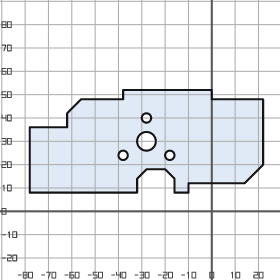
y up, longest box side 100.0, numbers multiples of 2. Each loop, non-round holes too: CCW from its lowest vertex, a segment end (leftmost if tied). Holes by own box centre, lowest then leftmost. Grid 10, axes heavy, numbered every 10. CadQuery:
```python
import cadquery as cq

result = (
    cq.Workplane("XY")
    .moveTo(-78.0, 8.0)
    .lineTo(-32.0, 8.0)
    .lineTo(-32.0, 14.0)
    .lineTo(-28.0, 18.0)
    .lineTo(-20.0, 18.0)
    .lineTo(-16.0, 14.0)
    .lineTo(-16.0, 8.0)
    .lineTo(-10.0, 8.0)
    .lineTo(-10.0, 12.0)
    .lineTo(14.0, 12.0)
    .lineTo(22.0, 20.0)
    .lineTo(22.0, 48.0)
    .lineTo(0.0, 48.0)
    .lineTo(0.0, 52.0)
    .lineTo(-38.0, 52.0)
    .lineTo(-38.0, 48.0)
    .lineTo(-56.0, 48.0)
    .lineTo(-62.0, 42.0)
    .lineTo(-62.0, 36.0)
    .lineTo(-78.0, 36.0)
    .close()
    .moveTo(-38.0, 24.0)
    .circle(2.0)
    .moveTo(-18.0, 24.0)
    .circle(2.0)
    .moveTo(-28.0, 30.0)
    .circle(4.0)
    .moveTo(-28.0, 40.0)
    .circle(2.0)
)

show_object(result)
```